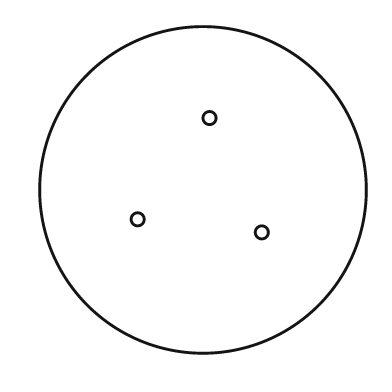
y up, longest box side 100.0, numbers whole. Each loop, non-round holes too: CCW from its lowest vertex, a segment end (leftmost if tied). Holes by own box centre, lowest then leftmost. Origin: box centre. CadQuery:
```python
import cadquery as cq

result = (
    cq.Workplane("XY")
    .moveTo(0.0, 0.0)
    .circle(50.0)
    .moveTo(18.0, -13.0)
    .circle(2.0)
    .moveTo(-20.0, -9.0)
    .circle(2.0)
    .moveTo(2.0, 22.0)
    .circle(2.0)
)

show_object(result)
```